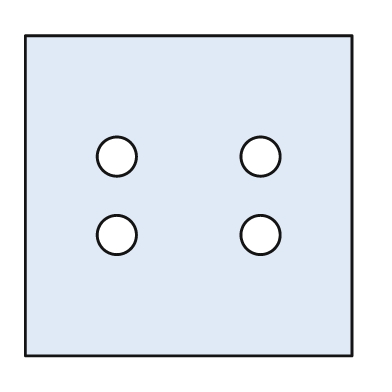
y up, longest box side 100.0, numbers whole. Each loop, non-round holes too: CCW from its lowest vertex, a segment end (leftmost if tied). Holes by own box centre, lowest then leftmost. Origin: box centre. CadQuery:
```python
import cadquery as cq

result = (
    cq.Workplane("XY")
    .moveTo(-50.0, -49.0)
    .lineTo(50.0, -49.0)
    .lineTo(50.0, 49.0)
    .lineTo(-50.0, 49.0)
    .close()
    .moveTo(-22.0, -12.0)
    .circle(6.0)
    .moveTo(22.0, -12.0)
    .circle(6.0)
    .moveTo(-22.0, 12.0)
    .circle(6.0)
    .moveTo(22.0, 12.0)
    .circle(6.0)
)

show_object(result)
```